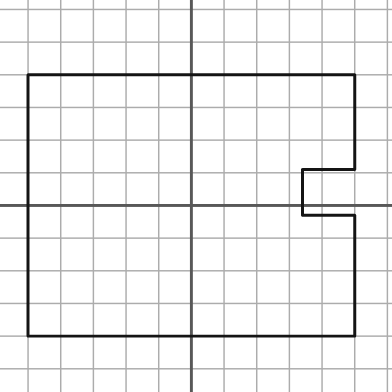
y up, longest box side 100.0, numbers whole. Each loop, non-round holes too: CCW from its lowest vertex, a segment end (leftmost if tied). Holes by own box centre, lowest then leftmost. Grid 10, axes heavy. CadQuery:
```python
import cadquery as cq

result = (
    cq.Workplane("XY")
    .moveTo(-50.0, -40.0)
    .lineTo(50.0, -40.0)
    .lineTo(50.0, -3.0)
    .lineTo(34.0, -3.0)
    .lineTo(34.0, 11.0)
    .lineTo(50.0, 11.0)
    .lineTo(50.0, 40.0)
    .lineTo(-50.0, 40.0)
    .close()
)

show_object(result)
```